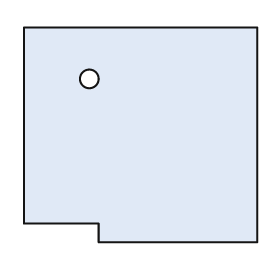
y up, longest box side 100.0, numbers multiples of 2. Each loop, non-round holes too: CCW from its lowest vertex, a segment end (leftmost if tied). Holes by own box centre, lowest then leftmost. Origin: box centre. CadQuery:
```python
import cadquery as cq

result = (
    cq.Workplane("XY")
    .moveTo(-18.0, -46.0)
    .lineTo(50.0, -46.0)
    .lineTo(50.0, 46.0)
    .lineTo(-50.0, 46.0)
    .lineTo(-50.0, -38.0)
    .lineTo(-18.0, -38.0)
    .close()
    .moveTo(-22.0, 24.0)
    .circle(4.0)
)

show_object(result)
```